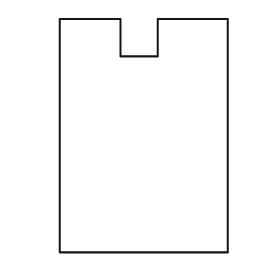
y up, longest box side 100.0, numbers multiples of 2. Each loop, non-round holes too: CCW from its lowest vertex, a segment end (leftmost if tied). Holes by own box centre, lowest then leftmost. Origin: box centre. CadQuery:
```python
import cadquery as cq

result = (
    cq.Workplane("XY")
    .moveTo(-36.0, -50.0)
    .lineTo(36.0, -50.0)
    .lineTo(36.0, 50.0)
    .lineTo(6.0, 50.0)
    .lineTo(6.0, 34.0)
    .lineTo(-10.0, 34.0)
    .lineTo(-10.0, 50.0)
    .lineTo(-36.0, 50.0)
    .close()
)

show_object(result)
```